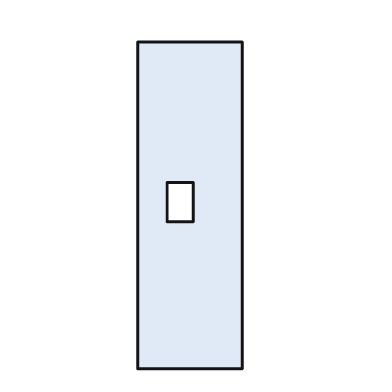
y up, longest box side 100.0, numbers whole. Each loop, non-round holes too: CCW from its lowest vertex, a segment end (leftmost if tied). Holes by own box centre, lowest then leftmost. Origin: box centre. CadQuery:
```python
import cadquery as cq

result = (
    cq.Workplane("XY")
    .moveTo(-16.0, -50.0)
    .lineTo(16.0, -50.0)
    .lineTo(16.0, 50.0)
    .lineTo(-16.0, 50.0)
    .close()
    .moveTo(-7.0, -5.0)
    .lineTo(1.0, -5.0)
    .lineTo(1.0, 7.0)
    .lineTo(-7.0, 7.0)
    .close()
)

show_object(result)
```